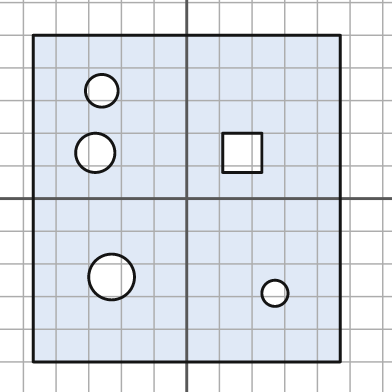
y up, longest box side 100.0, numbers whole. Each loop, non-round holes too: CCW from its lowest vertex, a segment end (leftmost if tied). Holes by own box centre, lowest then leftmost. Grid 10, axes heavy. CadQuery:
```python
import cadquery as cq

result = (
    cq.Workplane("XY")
    .moveTo(-47.0, -50.0)
    .lineTo(47.0, -50.0)
    .lineTo(47.0, 50.0)
    .lineTo(-47.0, 50.0)
    .close()
    .moveTo(27.0, -29.0)
    .circle(4.0)
    .moveTo(-23.0, -24.0)
    .circle(7.0)
    .moveTo(-28.0, 14.0)
    .circle(6.0)
    .moveTo(11.0, 8.0)
    .lineTo(23.0, 8.0)
    .lineTo(23.0, 20.0)
    .lineTo(11.0, 20.0)
    .close()
    .moveTo(-26.0, 33.0)
    .circle(5.0)
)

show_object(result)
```